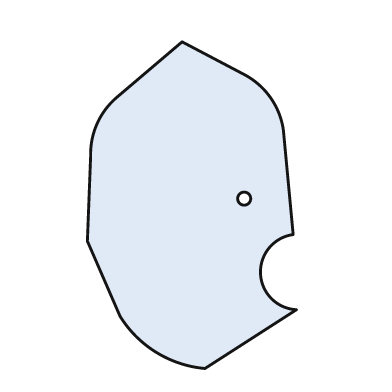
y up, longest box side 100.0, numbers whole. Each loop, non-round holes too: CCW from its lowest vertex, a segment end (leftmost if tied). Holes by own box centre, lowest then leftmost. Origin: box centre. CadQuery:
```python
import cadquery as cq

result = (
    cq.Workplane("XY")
    .moveTo(4.0, -50.0)
    .lineTo(32.0, -32.0)
    .threePointArc((21.0, -21.0), (31.0, -9.0))
    .lineTo(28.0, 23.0)
    .threePointArc((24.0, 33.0), (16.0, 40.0))
    .lineTo(-3.0, 50.0)
    .lineTo(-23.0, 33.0)
    .threePointArc((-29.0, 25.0), (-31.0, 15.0))
    .lineTo(-32.0, -11.0)
    .lineTo(-22.0, -34.0)
    .threePointArc((-11.0, -45.0), (4.0, -50.0))
    .close()
    .moveTo(16.0, 2.0)
    .circle(2.0)
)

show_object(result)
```